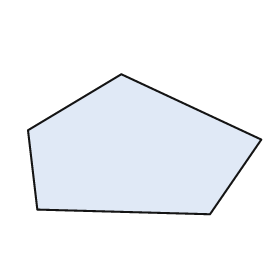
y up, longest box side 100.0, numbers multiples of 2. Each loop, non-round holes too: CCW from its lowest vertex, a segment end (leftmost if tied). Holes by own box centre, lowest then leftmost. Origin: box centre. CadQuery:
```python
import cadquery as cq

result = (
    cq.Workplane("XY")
    .moveTo(28.0, -30.0)
    .lineTo(50.0, 2.0)
    .lineTo(-10.0, 30.0)
    .lineTo(-50.0, 6.0)
    .lineTo(-46.0, -28.0)
    .close()
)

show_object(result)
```